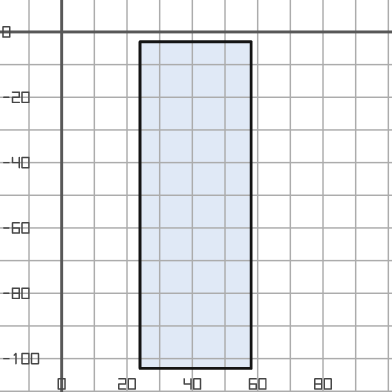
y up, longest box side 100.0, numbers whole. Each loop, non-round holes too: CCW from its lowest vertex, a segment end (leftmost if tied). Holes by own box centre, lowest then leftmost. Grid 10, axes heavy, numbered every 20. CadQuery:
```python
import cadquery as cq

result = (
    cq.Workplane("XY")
    .moveTo(24.0, -103.0)
    .lineTo(58.0, -103.0)
    .lineTo(58.0, -3.0)
    .lineTo(24.0, -3.0)
    .close()
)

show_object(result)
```